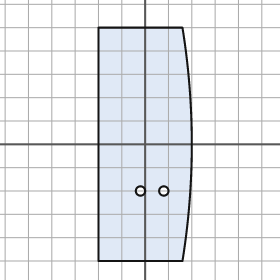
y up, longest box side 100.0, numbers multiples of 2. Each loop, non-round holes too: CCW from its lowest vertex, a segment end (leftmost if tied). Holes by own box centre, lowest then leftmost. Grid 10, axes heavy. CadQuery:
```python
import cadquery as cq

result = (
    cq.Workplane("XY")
    .moveTo(-20.0, -50.0)
    .lineTo(16.0, -50.0)
    .threePointArc((20.0, 0.0), (16.0, 50.0))
    .lineTo(-20.0, 50.0)
    .close()
    .moveTo(-2.0, -20.0)
    .circle(2.0)
    .moveTo(8.0, -20.0)
    .circle(2.0)
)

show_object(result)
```